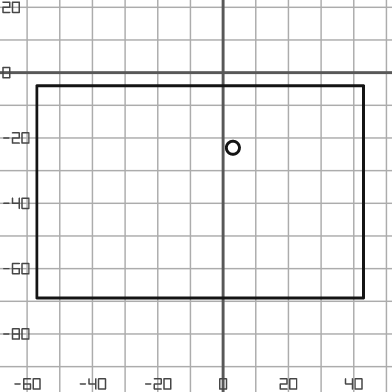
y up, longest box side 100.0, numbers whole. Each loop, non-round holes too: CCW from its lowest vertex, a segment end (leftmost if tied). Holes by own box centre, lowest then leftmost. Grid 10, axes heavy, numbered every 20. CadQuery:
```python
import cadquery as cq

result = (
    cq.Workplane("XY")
    .moveTo(-57.0, -69.0)
    .lineTo(43.0, -69.0)
    .lineTo(43.0, -4.0)
    .lineTo(-57.0, -4.0)
    .close()
    .moveTo(3.0, -23.0)
    .circle(2.0)
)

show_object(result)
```